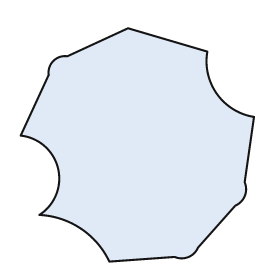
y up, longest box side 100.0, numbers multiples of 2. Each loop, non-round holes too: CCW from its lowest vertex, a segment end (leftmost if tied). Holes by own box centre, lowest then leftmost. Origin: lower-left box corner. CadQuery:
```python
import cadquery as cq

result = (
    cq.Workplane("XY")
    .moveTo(38.0, 0.0)
    .lineTo(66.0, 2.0)
    .threePointArc((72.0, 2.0), (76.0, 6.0))
    .lineTo(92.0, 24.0)
    .threePointArc((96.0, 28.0), (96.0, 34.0))
    .lineTo(100.0, 62.0)
    .threePointArc((84.0, 72.0), (80.0, 90.0))
    .lineTo(46.0, 100.0)
    .lineTo(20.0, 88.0)
    .threePointArc((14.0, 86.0), (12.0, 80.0))
    .lineTo(0.0, 54.0)
    .threePointArc((16.0, 40.0), (8.0, 20.0))
    .threePointArc((26.0, 14.0), (38.0, 0.0))
    .close()
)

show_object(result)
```